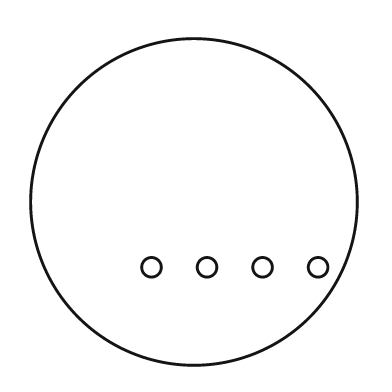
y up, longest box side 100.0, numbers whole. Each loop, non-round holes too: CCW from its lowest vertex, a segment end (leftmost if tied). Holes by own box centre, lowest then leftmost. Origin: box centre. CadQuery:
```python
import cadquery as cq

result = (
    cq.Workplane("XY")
    .moveTo(0.0, 0.0)
    .circle(50.0)
    .moveTo(-13.0, -20.0)
    .circle(3.0)
    .moveTo(4.0, -20.0)
    .circle(3.0)
    .moveTo(21.0, -20.0)
    .circle(3.0)
    .moveTo(38.0, -20.0)
    .circle(3.0)
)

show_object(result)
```